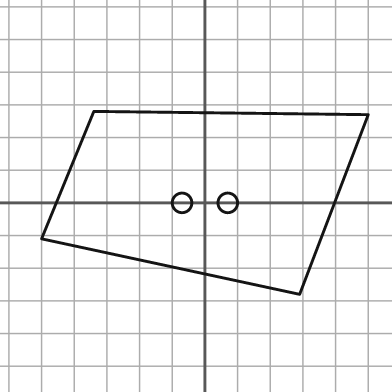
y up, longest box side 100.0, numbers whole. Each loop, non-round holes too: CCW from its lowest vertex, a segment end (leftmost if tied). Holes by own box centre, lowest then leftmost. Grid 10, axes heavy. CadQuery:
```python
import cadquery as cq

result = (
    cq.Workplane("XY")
    .moveTo(29.0, -28.0)
    .lineTo(50.0, 27.0)
    .lineTo(-34.0, 28.0)
    .lineTo(-50.0, -11.0)
    .close()
    .moveTo(-7.0, 0.0)
    .circle(3.0)
    .moveTo(7.0, 0.0)
    .circle(3.0)
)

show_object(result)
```